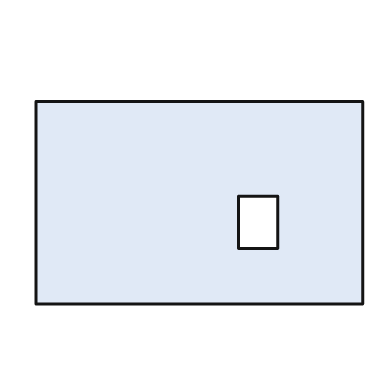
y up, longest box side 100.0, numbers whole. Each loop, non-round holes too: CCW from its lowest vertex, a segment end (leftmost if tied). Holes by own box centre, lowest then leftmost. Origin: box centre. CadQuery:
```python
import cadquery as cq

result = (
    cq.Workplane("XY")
    .moveTo(-50.0, -31.0)
    .lineTo(50.0, -31.0)
    .lineTo(50.0, 31.0)
    .lineTo(-50.0, 31.0)
    .close()
    .moveTo(12.0, -14.0)
    .lineTo(24.0, -14.0)
    .lineTo(24.0, 2.0)
    .lineTo(12.0, 2.0)
    .close()
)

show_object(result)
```